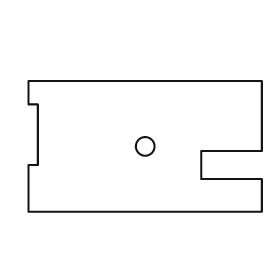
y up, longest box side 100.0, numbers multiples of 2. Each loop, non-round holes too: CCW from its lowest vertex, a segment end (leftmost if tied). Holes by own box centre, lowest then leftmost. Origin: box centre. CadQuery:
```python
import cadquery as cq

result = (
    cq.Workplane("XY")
    .moveTo(-50.0, -28.0)
    .lineTo(50.0, -28.0)
    .lineTo(50.0, -14.0)
    .lineTo(24.0, -14.0)
    .lineTo(24.0, -2.0)
    .lineTo(50.0, -2.0)
    .lineTo(50.0, 28.0)
    .lineTo(-50.0, 28.0)
    .lineTo(-50.0, 18.0)
    .lineTo(-46.0, 18.0)
    .lineTo(-46.0, -8.0)
    .lineTo(-50.0, -8.0)
    .close()
    .moveTo(0.0, 0.0)
    .circle(4.0)
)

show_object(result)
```